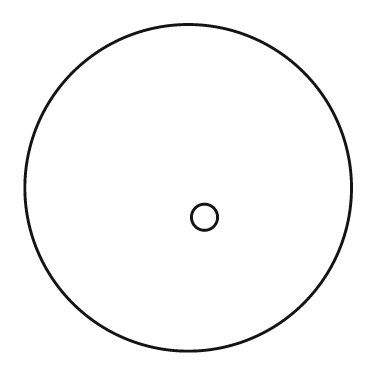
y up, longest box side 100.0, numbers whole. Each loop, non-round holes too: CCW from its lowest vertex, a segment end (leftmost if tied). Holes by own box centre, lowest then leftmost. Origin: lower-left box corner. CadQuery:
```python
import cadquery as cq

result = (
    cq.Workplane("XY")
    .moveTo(50.0, 50.0)
    .circle(50.0)
    .moveTo(55.0, 41.0)
    .circle(4.0)
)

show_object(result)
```